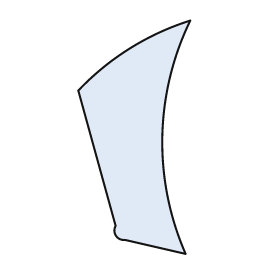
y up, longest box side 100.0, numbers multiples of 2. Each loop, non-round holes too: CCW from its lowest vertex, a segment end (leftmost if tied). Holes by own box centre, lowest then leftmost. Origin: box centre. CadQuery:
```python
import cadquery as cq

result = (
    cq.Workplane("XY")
    .moveTo(22.0, -50.0)
    .threePointArc((12.0, 0.0), (24.0, 50.0))
    .threePointArc((-2.0, 38.0), (-24.0, 20.0))
    .lineTo(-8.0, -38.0)
    .threePointArc((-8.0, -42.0), (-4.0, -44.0))
    .close()
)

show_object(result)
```